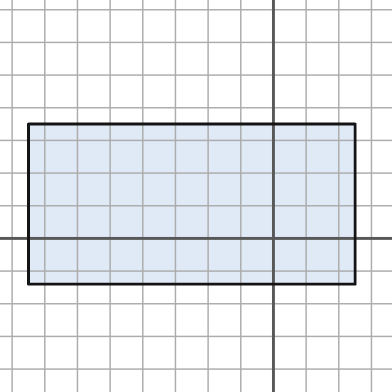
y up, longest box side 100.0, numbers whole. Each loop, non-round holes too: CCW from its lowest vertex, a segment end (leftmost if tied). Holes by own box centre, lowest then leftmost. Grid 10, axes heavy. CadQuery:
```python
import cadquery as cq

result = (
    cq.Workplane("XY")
    .moveTo(-75.0, -14.0)
    .lineTo(25.0, -14.0)
    .lineTo(25.0, 35.0)
    .lineTo(-75.0, 35.0)
    .close()
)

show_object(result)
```